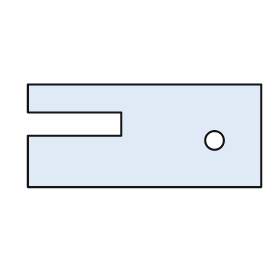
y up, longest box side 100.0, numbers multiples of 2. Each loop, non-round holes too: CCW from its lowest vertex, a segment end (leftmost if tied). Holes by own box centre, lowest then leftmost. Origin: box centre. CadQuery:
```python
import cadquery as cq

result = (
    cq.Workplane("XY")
    .moveTo(-50.0, -22.0)
    .lineTo(50.0, -22.0)
    .lineTo(50.0, 22.0)
    .lineTo(-50.0, 22.0)
    .lineTo(-50.0, 10.0)
    .lineTo(-10.0, 10.0)
    .lineTo(-10.0, 0.0)
    .lineTo(-50.0, 0.0)
    .close()
    .moveTo(30.0, -2.0)
    .circle(4.0)
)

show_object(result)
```